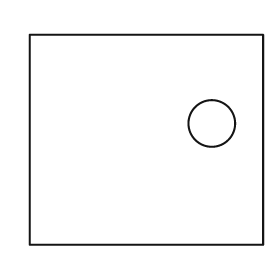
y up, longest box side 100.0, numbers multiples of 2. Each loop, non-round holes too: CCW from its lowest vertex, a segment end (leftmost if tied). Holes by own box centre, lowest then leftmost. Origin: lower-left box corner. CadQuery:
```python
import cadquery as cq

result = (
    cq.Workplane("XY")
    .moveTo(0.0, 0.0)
    .lineTo(100.0, 0.0)
    .lineTo(100.0, 90.0)
    .lineTo(0.0, 90.0)
    .close()
    .moveTo(78.0, 52.0)
    .circle(10.0)
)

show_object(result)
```